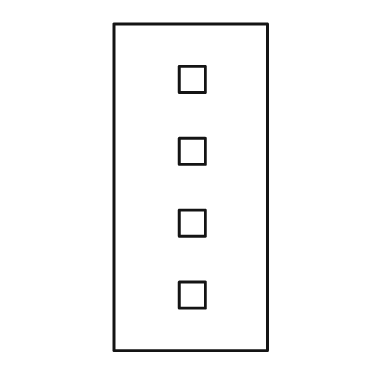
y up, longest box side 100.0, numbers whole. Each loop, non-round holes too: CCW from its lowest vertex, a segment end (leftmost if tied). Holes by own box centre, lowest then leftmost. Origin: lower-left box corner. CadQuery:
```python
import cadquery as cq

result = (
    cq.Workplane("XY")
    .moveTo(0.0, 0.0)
    .lineTo(47.0, 0.0)
    .lineTo(47.0, 100.0)
    .lineTo(0.0, 100.0)
    .close()
    .moveTo(20.0, 13.0)
    .lineTo(28.0, 13.0)
    .lineTo(28.0, 21.0)
    .lineTo(20.0, 21.0)
    .close()
    .moveTo(20.0, 35.0)
    .lineTo(28.0, 35.0)
    .lineTo(28.0, 43.0)
    .lineTo(20.0, 43.0)
    .close()
    .moveTo(20.0, 57.0)
    .lineTo(28.0, 57.0)
    .lineTo(28.0, 65.0)
    .lineTo(20.0, 65.0)
    .close()
    .moveTo(20.0, 79.0)
    .lineTo(28.0, 79.0)
    .lineTo(28.0, 87.0)
    .lineTo(20.0, 87.0)
    .close()
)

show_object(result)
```